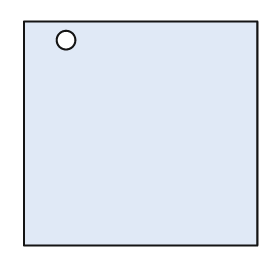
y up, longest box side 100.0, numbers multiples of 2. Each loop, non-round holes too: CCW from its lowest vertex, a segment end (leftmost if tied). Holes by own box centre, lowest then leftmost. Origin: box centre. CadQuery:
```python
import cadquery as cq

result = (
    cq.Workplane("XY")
    .moveTo(-50.0, -48.0)
    .lineTo(50.0, -48.0)
    .lineTo(50.0, 48.0)
    .lineTo(-50.0, 48.0)
    .close()
    .moveTo(-32.0, 40.0)
    .circle(4.0)
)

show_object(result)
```